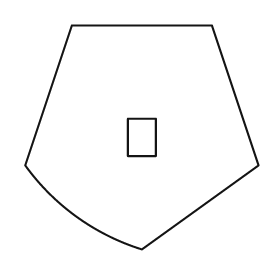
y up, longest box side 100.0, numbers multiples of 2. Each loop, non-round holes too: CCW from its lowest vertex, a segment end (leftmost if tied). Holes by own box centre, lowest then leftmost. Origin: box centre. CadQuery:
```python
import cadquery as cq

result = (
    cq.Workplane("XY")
    .moveTo(0.0, -48.0)
    .lineTo(50.0, -12.0)
    .lineTo(30.0, 48.0)
    .lineTo(-30.0, 48.0)
    .lineTo(-50.0, -12.0)
    .threePointArc((-28.0, -34.0), (0.0, -48.0))
    .close()
    .moveTo(-6.0, -8.0)
    .lineTo(6.0, -8.0)
    .lineTo(6.0, 8.0)
    .lineTo(-6.0, 8.0)
    .close()
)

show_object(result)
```